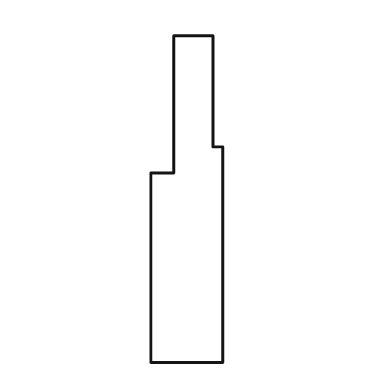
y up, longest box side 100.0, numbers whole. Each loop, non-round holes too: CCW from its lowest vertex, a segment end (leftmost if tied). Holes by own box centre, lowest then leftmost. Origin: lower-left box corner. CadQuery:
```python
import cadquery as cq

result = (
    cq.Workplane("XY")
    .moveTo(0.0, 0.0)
    .lineTo(22.0, 0.0)
    .lineTo(22.0, 66.0)
    .lineTo(19.0, 66.0)
    .lineTo(19.0, 100.0)
    .lineTo(7.0, 100.0)
    .lineTo(7.0, 58.0)
    .lineTo(0.0, 58.0)
    .close()
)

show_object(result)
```